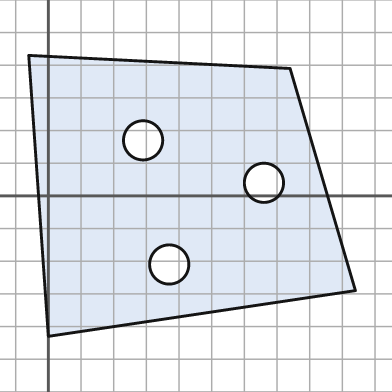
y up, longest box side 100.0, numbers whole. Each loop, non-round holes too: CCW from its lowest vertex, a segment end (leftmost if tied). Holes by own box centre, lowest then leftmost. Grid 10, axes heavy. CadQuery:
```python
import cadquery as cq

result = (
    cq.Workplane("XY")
    .moveTo(0.0, -43.0)
    .lineTo(94.0, -29.0)
    .lineTo(74.0, 39.0)
    .lineTo(-6.0, 43.0)
    .close()
    .moveTo(37.0, -21.0)
    .circle(6.0)
    .moveTo(66.0, 4.0)
    .circle(6.0)
    .moveTo(29.0, 17.0)
    .circle(6.0)
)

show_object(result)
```